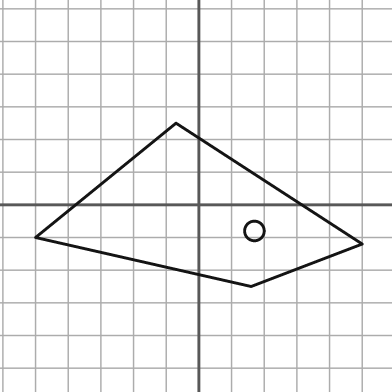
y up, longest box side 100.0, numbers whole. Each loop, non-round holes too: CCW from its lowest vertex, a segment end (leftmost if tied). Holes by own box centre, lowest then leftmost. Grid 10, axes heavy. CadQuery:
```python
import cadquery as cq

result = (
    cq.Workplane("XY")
    .moveTo(16.0, -25.0)
    .lineTo(50.0, -12.0)
    .lineTo(-7.0, 25.0)
    .lineTo(-50.0, -10.0)
    .close()
    .moveTo(17.0, -8.0)
    .circle(3.0)
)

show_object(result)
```